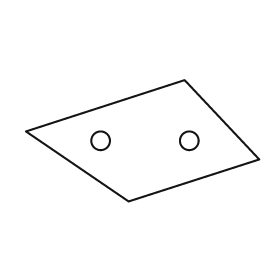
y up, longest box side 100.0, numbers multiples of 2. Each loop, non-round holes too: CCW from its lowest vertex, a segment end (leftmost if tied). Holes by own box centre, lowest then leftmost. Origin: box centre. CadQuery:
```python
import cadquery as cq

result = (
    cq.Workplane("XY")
    .moveTo(-6.0, -26.0)
    .lineTo(50.0, -8.0)
    .lineTo(18.0, 26.0)
    .lineTo(-50.0, 4.0)
    .close()
    .moveTo(-18.0, 0.0)
    .circle(4.0)
    .moveTo(20.0, 0.0)
    .circle(4.0)
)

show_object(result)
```